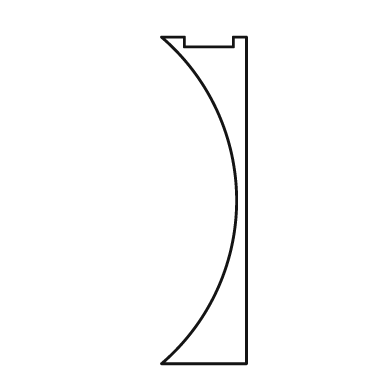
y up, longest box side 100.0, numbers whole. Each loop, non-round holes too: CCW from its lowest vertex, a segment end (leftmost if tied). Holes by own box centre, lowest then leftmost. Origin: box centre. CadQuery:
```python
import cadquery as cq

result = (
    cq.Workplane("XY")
    .moveTo(-13.0, -50.0)
    .lineTo(13.0, -50.0)
    .lineTo(13.0, 50.0)
    .lineTo(9.0, 50.0)
    .lineTo(9.0, 47.0)
    .lineTo(-6.0, 47.0)
    .lineTo(-6.0, 50.0)
    .lineTo(-13.0, 50.0)
    .threePointArc((10.0, 0.0), (-13.0, -50.0))
    .close()
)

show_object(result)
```